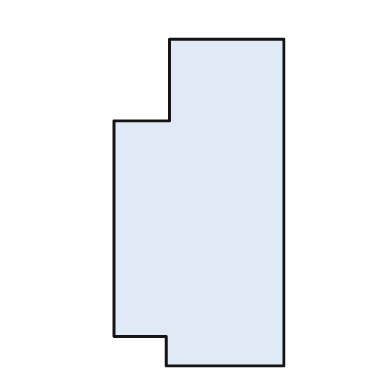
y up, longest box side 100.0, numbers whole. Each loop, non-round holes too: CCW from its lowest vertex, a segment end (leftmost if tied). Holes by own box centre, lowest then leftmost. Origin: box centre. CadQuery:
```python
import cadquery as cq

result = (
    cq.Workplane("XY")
    .moveTo(-10.0, -50.0)
    .lineTo(26.0, -50.0)
    .lineTo(26.0, 50.0)
    .lineTo(-9.0, 50.0)
    .lineTo(-9.0, 25.0)
    .lineTo(-26.0, 25.0)
    .lineTo(-26.0, -41.0)
    .lineTo(-10.0, -41.0)
    .close()
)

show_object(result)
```